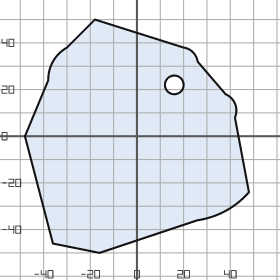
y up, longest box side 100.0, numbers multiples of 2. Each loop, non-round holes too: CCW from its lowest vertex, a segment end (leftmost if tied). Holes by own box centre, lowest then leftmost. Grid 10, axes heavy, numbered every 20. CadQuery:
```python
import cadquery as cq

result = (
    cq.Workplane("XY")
    .moveTo(-16.0, -50.0)
    .lineTo(26.0, -36.0)
    .threePointArc((38.0, -32.0), (48.0, -24.0))
    .lineTo(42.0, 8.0)
    .threePointArc((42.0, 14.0), (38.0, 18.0))
    .lineTo(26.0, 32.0)
    .threePointArc((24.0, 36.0), (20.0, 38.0))
    .lineTo(-18.0, 50.0)
    .lineTo(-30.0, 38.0)
    .threePointArc((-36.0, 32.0), (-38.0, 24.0))
    .lineTo(-48.0, 0.0)
    .lineTo(-36.0, -46.0)
    .close()
    .moveTo(16.0, 22.0)
    .circle(4.0)
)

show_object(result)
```